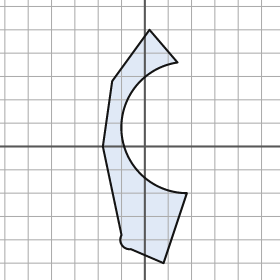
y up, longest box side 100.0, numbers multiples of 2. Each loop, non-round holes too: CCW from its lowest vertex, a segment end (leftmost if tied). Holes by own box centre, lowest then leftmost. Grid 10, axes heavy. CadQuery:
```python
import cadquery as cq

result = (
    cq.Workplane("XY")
    .moveTo(8.0, -50.0)
    .lineTo(18.0, -20.0)
    .threePointArc((-10.0, 6.0), (14.0, 36.0))
    .lineTo(2.0, 50.0)
    .lineTo(-14.0, 28.0)
    .lineTo(-18.0, 0.0)
    .lineTo(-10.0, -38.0)
    .threePointArc((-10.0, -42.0), (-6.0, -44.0))
    .close()
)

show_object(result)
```